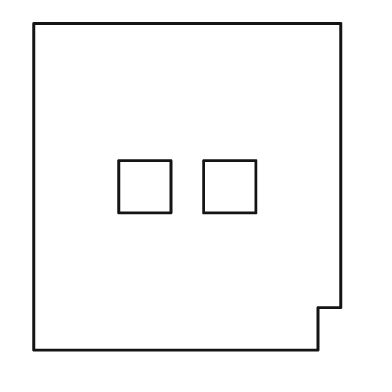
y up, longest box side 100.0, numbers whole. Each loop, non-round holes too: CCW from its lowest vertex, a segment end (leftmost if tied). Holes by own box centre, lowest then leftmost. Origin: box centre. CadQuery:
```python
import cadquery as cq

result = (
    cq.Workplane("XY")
    .moveTo(-47.0, -50.0)
    .lineTo(40.0, -50.0)
    .lineTo(40.0, -37.0)
    .lineTo(47.0, -37.0)
    .lineTo(47.0, 50.0)
    .lineTo(-47.0, 50.0)
    .close()
    .moveTo(-21.0, -8.0)
    .lineTo(-5.0, -8.0)
    .lineTo(-5.0, 8.0)
    .lineTo(-21.0, 8.0)
    .close()
    .moveTo(5.0, -8.0)
    .lineTo(21.0, -8.0)
    .lineTo(21.0, 8.0)
    .lineTo(5.0, 8.0)
    .close()
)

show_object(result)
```